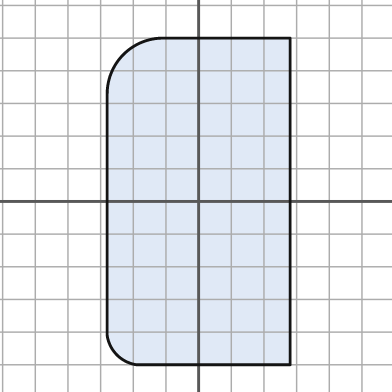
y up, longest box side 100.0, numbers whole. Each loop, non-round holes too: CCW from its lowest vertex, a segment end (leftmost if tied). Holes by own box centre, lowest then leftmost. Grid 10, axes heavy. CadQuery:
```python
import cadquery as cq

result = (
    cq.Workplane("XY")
    .moveTo(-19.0, -50.0)
    .lineTo(28.0, -50.0)
    .lineTo(28.0, 50.0)
    .lineTo(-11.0, 50.0)
    .threePointArc((-23.0, 45.0), (-28.0, 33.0))
    .lineTo(-28.0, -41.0)
    .threePointArc((-25.0, -47.0), (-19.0, -50.0))
    .close()
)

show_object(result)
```